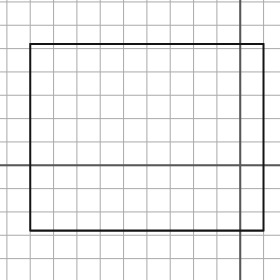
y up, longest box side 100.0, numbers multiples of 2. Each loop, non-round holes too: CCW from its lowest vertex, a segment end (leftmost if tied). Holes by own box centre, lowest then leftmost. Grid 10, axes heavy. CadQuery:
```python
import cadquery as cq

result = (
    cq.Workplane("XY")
    .moveTo(-90.0, -28.0)
    .lineTo(10.0, -28.0)
    .lineTo(10.0, 52.0)
    .lineTo(-90.0, 52.0)
    .close()
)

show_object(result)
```